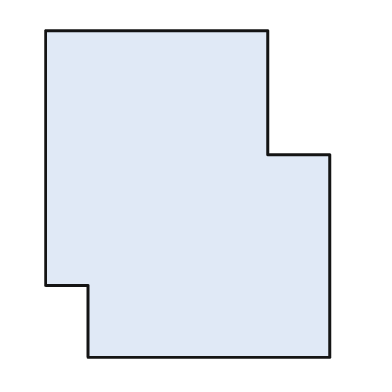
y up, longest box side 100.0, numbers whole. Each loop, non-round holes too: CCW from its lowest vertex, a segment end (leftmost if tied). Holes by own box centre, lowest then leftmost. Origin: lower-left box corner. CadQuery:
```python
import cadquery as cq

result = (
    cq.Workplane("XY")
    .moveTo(13.0, 0.0)
    .lineTo(87.0, 0.0)
    .lineTo(87.0, 62.0)
    .lineTo(68.0, 62.0)
    .lineTo(68.0, 100.0)
    .lineTo(0.0, 100.0)
    .lineTo(0.0, 22.0)
    .lineTo(13.0, 22.0)
    .close()
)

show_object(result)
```